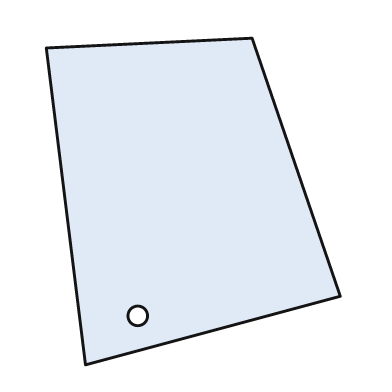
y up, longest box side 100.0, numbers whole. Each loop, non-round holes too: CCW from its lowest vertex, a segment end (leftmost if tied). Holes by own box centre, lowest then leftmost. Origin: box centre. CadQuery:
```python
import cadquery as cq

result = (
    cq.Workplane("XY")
    .moveTo(-33.0, -50.0)
    .lineTo(45.0, -29.0)
    .lineTo(18.0, 50.0)
    .lineTo(-45.0, 47.0)
    .close()
    .moveTo(-17.0, -35.0)
    .circle(3.0)
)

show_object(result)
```